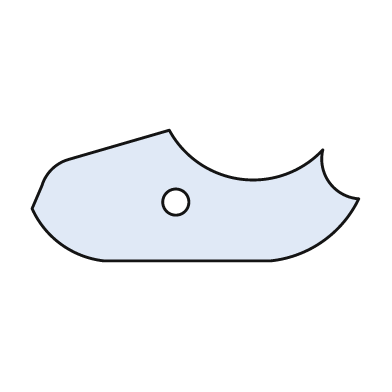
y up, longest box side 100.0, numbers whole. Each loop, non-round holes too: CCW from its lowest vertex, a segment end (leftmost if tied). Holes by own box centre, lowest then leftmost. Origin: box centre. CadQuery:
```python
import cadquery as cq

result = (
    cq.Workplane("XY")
    .moveTo(-28.0, -20.0)
    .lineTo(23.0, -20.0)
    .threePointArc((39.0, -14.0), (50.0, -1.0))
    .threePointArc((41.0, 4.0), (39.0, 14.0))
    .threePointArc((14.0, 5.0), (-8.0, 20.0))
    .lineTo(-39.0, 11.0)
    .threePointArc((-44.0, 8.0), (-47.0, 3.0))
    .lineTo(-50.0, -4.0)
    .threePointArc((-41.0, -15.0), (-28.0, -20.0))
    .close()
    .moveTo(-6.0, -2.0)
    .circle(4.0)
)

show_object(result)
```